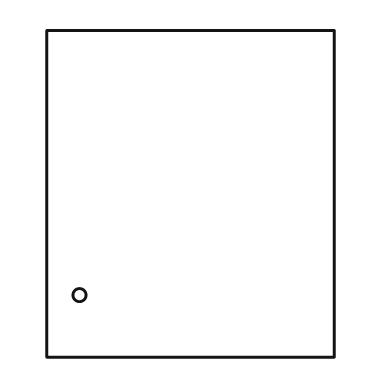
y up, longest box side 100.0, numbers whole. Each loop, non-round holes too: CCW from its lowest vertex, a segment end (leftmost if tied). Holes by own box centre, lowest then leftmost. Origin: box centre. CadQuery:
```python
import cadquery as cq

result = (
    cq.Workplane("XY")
    .moveTo(-44.0, -50.0)
    .lineTo(44.0, -50.0)
    .lineTo(44.0, 50.0)
    .lineTo(-44.0, 50.0)
    .close()
    .moveTo(-34.0, -31.0)
    .circle(2.0)
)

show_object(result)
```